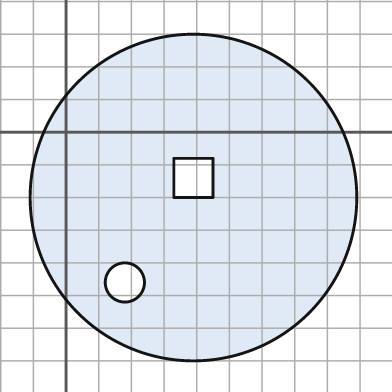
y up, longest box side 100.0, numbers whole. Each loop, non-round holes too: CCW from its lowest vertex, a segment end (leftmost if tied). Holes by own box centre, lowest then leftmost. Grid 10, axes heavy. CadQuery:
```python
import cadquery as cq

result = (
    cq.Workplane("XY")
    .moveTo(39.0, -20.0)
    .circle(50.0)
    .moveTo(18.0, -46.0)
    .circle(6.0)
    .moveTo(33.0, -20.0)
    .lineTo(45.0, -20.0)
    .lineTo(45.0, -8.0)
    .lineTo(33.0, -8.0)
    .close()
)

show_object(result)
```